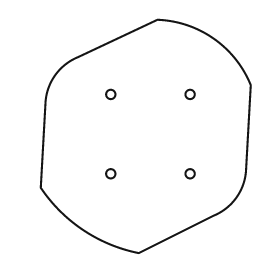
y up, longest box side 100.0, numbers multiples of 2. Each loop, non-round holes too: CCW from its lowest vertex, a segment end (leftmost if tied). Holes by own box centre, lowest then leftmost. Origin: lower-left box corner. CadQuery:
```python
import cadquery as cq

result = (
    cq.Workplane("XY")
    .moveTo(42.0, 0.0)
    .lineTo(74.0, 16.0)
    .threePointArc((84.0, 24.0), (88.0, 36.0))
    .lineTo(90.0, 72.0)
    .threePointArc((74.0, 92.0), (50.0, 100.0))
    .lineTo(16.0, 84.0)
    .threePointArc((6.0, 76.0), (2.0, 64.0))
    .lineTo(0.0, 28.0)
    .threePointArc((18.0, 10.0), (42.0, 0.0))
    .close()
    .moveTo(30.0, 34.0)
    .circle(2.0)
    .moveTo(64.0, 34.0)
    .circle(2.0)
    .moveTo(30.0, 68.0)
    .circle(2.0)
    .moveTo(64.0, 68.0)
    .circle(2.0)
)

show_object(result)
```